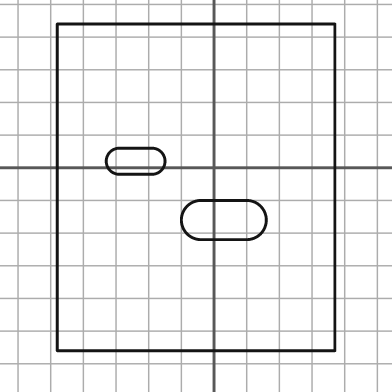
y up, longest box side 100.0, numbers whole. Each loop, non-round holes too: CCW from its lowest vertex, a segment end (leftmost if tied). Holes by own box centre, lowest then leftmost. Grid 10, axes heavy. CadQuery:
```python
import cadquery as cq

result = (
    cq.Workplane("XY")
    .moveTo(-48.0, -56.0)
    .lineTo(37.0, -56.0)
    .lineTo(37.0, 44.0)
    .lineTo(-48.0, 44.0)
    .close()
    .moveTo(-4.0, -22.0)
    .lineTo(10.0, -22.0)
    .threePointArc((16.0, -16.0), (10.0, -10.0))
    .lineTo(-4.0, -10.0)
    .threePointArc((-10.0, -16.0), (-4.0, -22.0))
    .close()
    .moveTo(-29.0, -2.0)
    .lineTo(-19.0, -2.0)
    .threePointArc((-15.0, 2.0), (-19.0, 6.0))
    .lineTo(-29.0, 6.0)
    .threePointArc((-33.0, 2.0), (-29.0, -2.0))
    .close()
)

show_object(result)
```